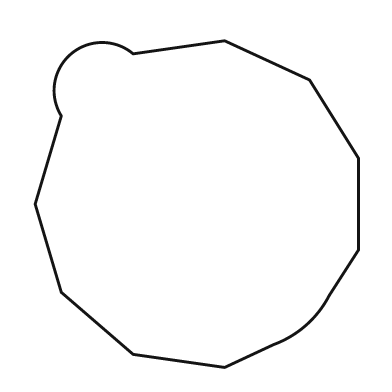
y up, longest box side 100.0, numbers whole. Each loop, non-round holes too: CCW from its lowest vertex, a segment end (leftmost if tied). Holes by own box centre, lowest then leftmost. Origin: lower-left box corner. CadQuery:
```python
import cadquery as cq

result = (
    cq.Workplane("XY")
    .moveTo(58.0, 0.0)
    .lineTo(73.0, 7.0)
    .threePointArc((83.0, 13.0), (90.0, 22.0))
    .lineTo(99.0, 36.0)
    .lineTo(99.0, 64.0)
    .lineTo(84.0, 88.0)
    .lineTo(58.0, 100.0)
    .lineTo(30.0, 96.0)
    .threePointArc((11.0, 96.0), (8.0, 77.0))
    .lineTo(0.0, 50.0)
    .lineTo(8.0, 23.0)
    .lineTo(30.0, 4.0)
    .close()
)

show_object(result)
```